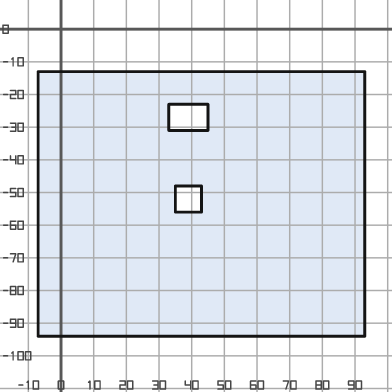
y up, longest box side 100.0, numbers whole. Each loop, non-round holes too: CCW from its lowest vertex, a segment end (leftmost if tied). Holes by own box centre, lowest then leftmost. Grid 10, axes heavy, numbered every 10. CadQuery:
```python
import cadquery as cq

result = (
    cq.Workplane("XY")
    .moveTo(-7.0, -94.0)
    .lineTo(93.0, -94.0)
    .lineTo(93.0, -13.0)
    .lineTo(-7.0, -13.0)
    .close()
    .moveTo(35.0, -56.0)
    .lineTo(43.0, -56.0)
    .lineTo(43.0, -48.0)
    .lineTo(35.0, -48.0)
    .close()
    .moveTo(33.0, -31.0)
    .lineTo(45.0, -31.0)
    .lineTo(45.0, -23.0)
    .lineTo(33.0, -23.0)
    .close()
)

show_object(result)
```